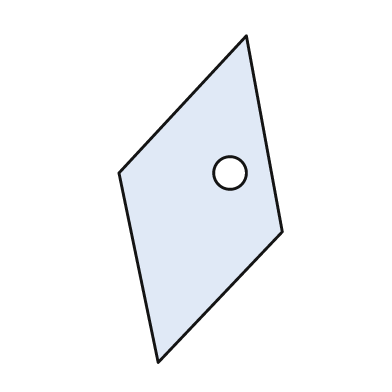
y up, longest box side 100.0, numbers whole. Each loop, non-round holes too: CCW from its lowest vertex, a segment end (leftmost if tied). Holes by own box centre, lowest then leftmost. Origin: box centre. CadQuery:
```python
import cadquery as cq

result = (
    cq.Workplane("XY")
    .moveTo(-13.0, -50.0)
    .lineTo(25.0, -10.0)
    .lineTo(14.0, 50.0)
    .lineTo(-25.0, 8.0)
    .close()
    .moveTo(9.0, 8.0)
    .circle(5.0)
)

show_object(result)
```